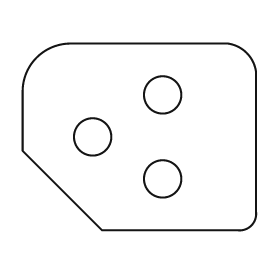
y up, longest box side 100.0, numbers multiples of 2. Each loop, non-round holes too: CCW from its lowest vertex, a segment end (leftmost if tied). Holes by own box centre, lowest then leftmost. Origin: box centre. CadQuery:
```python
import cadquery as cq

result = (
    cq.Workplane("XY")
    .moveTo(-16.0, -40.0)
    .lineTo(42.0, -40.0)
    .threePointArc((48.0, -38.0), (50.0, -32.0))
    .lineTo(50.0, 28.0)
    .threePointArc((46.0, 36.0), (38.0, 40.0))
    .lineTo(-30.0, 40.0)
    .threePointArc((-44.0, 34.0), (-50.0, 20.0))
    .lineTo(-50.0, -6.0)
    .close()
    .moveTo(10.0, -18.0)
    .circle(8.0)
    .moveTo(-20.0, 0.0)
    .circle(8.0)
    .moveTo(10.0, 18.0)
    .circle(8.0)
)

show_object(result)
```